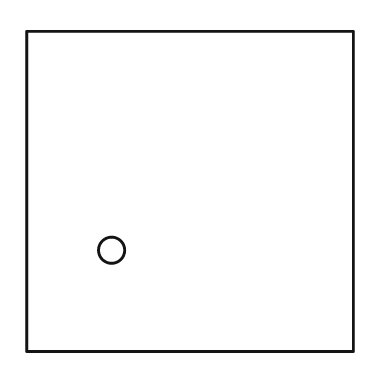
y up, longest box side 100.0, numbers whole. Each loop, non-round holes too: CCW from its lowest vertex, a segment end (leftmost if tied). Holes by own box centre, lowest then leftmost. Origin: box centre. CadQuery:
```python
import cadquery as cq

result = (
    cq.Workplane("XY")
    .moveTo(-50.0, -49.0)
    .lineTo(50.0, -49.0)
    .lineTo(50.0, 49.0)
    .lineTo(-50.0, 49.0)
    .close()
    .moveTo(-24.0, -18.0)
    .circle(4.0)
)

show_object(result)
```